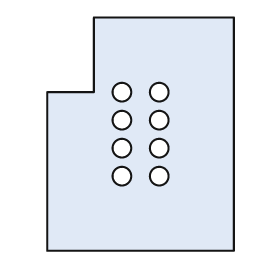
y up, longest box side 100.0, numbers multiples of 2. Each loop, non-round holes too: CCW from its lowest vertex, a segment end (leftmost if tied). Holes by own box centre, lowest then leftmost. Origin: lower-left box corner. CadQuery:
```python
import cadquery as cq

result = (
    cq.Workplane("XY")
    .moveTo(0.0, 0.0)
    .lineTo(80.0, 0.0)
    .lineTo(80.0, 100.0)
    .lineTo(20.0, 100.0)
    .lineTo(20.0, 68.0)
    .lineTo(0.0, 68.0)
    .close()
    .moveTo(32.0, 32.0)
    .circle(4.0)
    .moveTo(48.0, 32.0)
    .circle(4.0)
    .moveTo(32.0, 44.0)
    .circle(4.0)
    .moveTo(48.0, 44.0)
    .circle(4.0)
    .moveTo(32.0, 56.0)
    .circle(4.0)
    .moveTo(48.0, 56.0)
    .circle(4.0)
    .moveTo(32.0, 68.0)
    .circle(4.0)
    .moveTo(48.0, 68.0)
    .circle(4.0)
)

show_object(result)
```